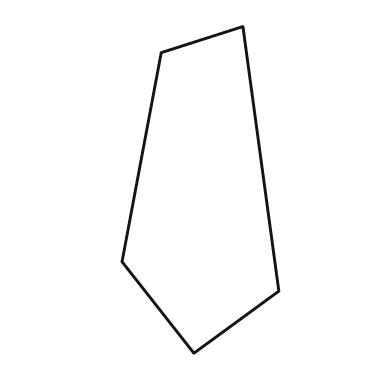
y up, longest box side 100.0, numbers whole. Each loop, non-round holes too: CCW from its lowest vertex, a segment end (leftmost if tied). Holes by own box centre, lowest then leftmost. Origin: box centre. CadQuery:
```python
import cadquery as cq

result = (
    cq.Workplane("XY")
    .moveTo(-2.0, -50.0)
    .lineTo(24.0, -31.0)
    .lineTo(13.0, 50.0)
    .lineTo(-12.0, 42.0)
    .lineTo(-24.0, -22.0)
    .close()
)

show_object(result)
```